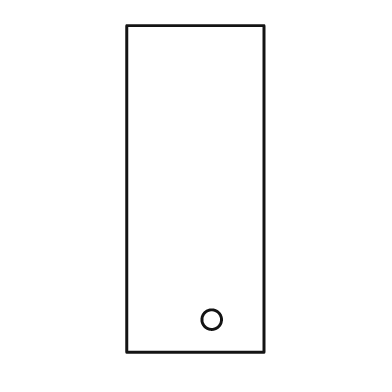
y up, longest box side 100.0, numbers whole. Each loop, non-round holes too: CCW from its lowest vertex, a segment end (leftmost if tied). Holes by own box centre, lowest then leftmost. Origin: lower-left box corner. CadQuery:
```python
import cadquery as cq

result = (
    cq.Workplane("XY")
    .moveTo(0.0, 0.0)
    .lineTo(42.0, 0.0)
    .lineTo(42.0, 100.0)
    .lineTo(0.0, 100.0)
    .close()
    .moveTo(26.0, 10.0)
    .circle(3.0)
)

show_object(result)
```